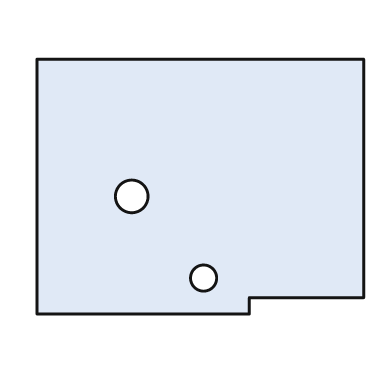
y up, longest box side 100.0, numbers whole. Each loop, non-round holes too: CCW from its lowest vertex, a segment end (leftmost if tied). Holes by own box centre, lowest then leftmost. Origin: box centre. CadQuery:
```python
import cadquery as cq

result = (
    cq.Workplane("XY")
    .moveTo(-50.0, -39.0)
    .lineTo(15.0, -39.0)
    .lineTo(15.0, -34.0)
    .lineTo(50.0, -34.0)
    .lineTo(50.0, 39.0)
    .lineTo(-50.0, 39.0)
    .close()
    .moveTo(1.0, -28.0)
    .circle(4.0)
    .moveTo(-21.0, -3.0)
    .circle(5.0)
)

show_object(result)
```